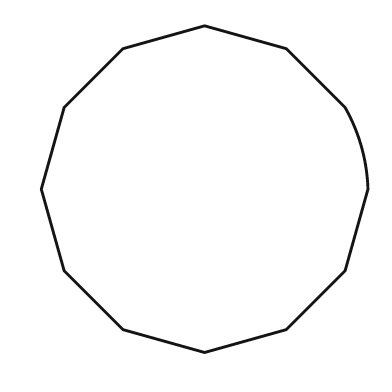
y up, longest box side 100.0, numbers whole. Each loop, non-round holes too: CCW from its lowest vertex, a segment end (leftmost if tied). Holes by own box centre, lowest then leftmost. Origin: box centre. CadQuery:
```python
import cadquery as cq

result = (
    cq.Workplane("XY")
    .moveTo(0.0, -50.0)
    .lineTo(25.0, -43.0)
    .lineTo(43.0, -25.0)
    .lineTo(50.0, 0.0)
    .threePointArc((48.0, 13.0), (43.0, 25.0))
    .lineTo(25.0, 43.0)
    .lineTo(0.0, 50.0)
    .lineTo(-25.0, 43.0)
    .lineTo(-43.0, 25.0)
    .lineTo(-50.0, 0.0)
    .lineTo(-43.0, -25.0)
    .lineTo(-25.0, -43.0)
    .close()
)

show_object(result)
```